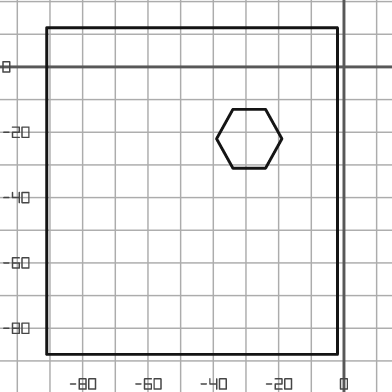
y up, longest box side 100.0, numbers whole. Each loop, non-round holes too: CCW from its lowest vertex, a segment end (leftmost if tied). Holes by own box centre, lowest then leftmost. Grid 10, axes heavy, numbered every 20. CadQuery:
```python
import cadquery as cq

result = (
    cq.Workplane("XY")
    .moveTo(-91.0, -88.0)
    .lineTo(-2.0, -88.0)
    .lineTo(-2.0, 12.0)
    .lineTo(-91.0, 12.0)
    .close()
    .moveTo(-34.0, -31.0)
    .lineTo(-24.0, -31.0)
    .lineTo(-19.0, -22.0)
    .lineTo(-24.0, -13.0)
    .lineTo(-34.0, -13.0)
    .lineTo(-39.0, -22.0)
    .close()
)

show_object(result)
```